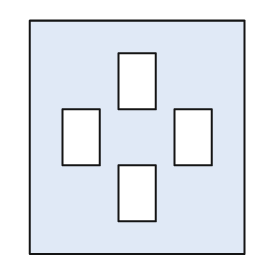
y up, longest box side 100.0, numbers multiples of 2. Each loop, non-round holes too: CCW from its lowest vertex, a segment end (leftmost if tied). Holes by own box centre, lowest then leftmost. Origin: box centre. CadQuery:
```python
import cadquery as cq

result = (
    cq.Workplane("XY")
    .moveTo(-46.0, -50.0)
    .lineTo(46.0, -50.0)
    .lineTo(46.0, 50.0)
    .lineTo(-46.0, 50.0)
    .close()
    .moveTo(-8.0, -36.0)
    .lineTo(8.0, -36.0)
    .lineTo(8.0, -12.0)
    .lineTo(-8.0, -12.0)
    .close()
    .moveTo(-32.0, -12.0)
    .lineTo(-16.0, -12.0)
    .lineTo(-16.0, 12.0)
    .lineTo(-32.0, 12.0)
    .close()
    .moveTo(16.0, -12.0)
    .lineTo(32.0, -12.0)
    .lineTo(32.0, 12.0)
    .lineTo(16.0, 12.0)
    .close()
    .moveTo(-8.0, 12.0)
    .lineTo(8.0, 12.0)
    .lineTo(8.0, 36.0)
    .lineTo(-8.0, 36.0)
    .close()
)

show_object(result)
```